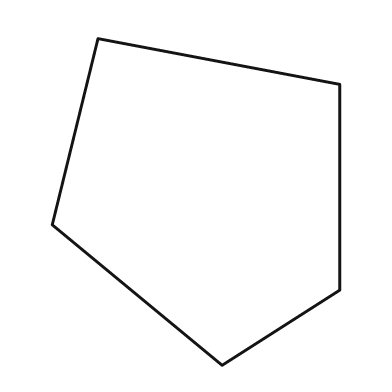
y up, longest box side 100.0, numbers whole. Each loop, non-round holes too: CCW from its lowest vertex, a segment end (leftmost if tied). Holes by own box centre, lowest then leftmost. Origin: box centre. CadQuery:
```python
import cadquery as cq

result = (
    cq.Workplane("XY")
    .moveTo(8.0, -50.0)
    .lineTo(44.0, -27.0)
    .lineTo(44.0, 36.0)
    .lineTo(-30.0, 50.0)
    .lineTo(-44.0, -7.0)
    .close()
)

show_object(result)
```